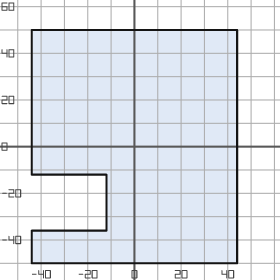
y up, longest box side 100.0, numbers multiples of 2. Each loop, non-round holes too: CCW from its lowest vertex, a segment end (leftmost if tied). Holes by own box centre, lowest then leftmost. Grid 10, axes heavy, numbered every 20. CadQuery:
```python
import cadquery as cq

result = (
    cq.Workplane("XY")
    .moveTo(-44.0, -50.0)
    .lineTo(44.0, -50.0)
    .lineTo(44.0, 50.0)
    .lineTo(-44.0, 50.0)
    .lineTo(-44.0, -12.0)
    .lineTo(-12.0, -12.0)
    .lineTo(-12.0, -36.0)
    .lineTo(-44.0, -36.0)
    .close()
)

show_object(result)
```